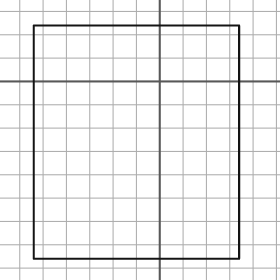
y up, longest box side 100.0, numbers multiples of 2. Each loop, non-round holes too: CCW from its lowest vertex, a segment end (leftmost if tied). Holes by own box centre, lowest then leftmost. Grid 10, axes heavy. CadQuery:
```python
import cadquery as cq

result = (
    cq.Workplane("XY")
    .moveTo(-54.0, -76.0)
    .lineTo(34.0, -76.0)
    .lineTo(34.0, 24.0)
    .lineTo(-54.0, 24.0)
    .close()
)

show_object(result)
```